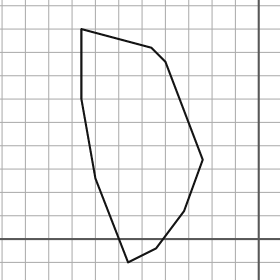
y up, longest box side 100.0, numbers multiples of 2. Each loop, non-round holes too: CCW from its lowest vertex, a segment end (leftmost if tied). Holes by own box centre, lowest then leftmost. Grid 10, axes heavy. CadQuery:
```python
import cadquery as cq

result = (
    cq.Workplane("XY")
    .moveTo(-56.0, -10.0)
    .lineTo(-44.0, -4.0)
    .lineTo(-32.0, 12.0)
    .lineTo(-24.0, 34.0)
    .lineTo(-40.0, 76.0)
    .lineTo(-46.0, 82.0)
    .lineTo(-76.0, 90.0)
    .lineTo(-76.0, 60.0)
    .lineTo(-70.0, 26.0)
    .close()
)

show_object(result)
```